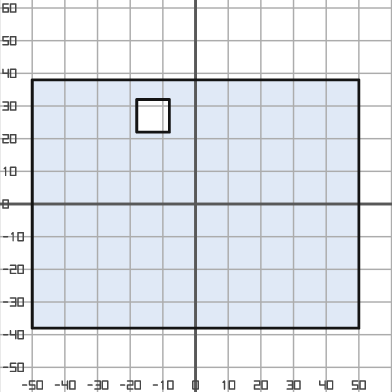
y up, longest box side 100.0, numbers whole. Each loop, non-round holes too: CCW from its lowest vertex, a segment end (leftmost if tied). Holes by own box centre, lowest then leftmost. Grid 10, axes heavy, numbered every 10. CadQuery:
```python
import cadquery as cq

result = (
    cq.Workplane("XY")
    .moveTo(-50.0, -38.0)
    .lineTo(50.0, -38.0)
    .lineTo(50.0, 38.0)
    .lineTo(-50.0, 38.0)
    .close()
    .moveTo(-18.0, 22.0)
    .lineTo(-8.0, 22.0)
    .lineTo(-8.0, 32.0)
    .lineTo(-18.0, 32.0)
    .close()
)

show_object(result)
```